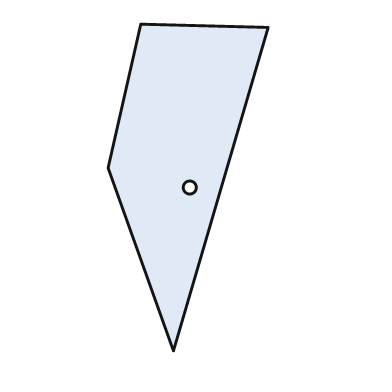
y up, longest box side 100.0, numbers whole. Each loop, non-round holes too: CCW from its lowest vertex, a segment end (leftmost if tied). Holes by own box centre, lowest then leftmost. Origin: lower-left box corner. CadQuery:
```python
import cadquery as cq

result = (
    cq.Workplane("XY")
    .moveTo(20.0, 0.0)
    .lineTo(49.0, 99.0)
    .lineTo(10.0, 100.0)
    .lineTo(0.0, 56.0)
    .close()
    .moveTo(25.0, 50.0)
    .circle(2.0)
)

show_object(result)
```